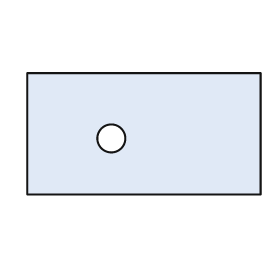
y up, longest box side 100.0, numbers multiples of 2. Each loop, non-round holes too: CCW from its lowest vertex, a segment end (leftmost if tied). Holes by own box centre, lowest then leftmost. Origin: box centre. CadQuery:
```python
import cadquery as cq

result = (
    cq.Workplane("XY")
    .moveTo(-50.0, -26.0)
    .lineTo(50.0, -26.0)
    .lineTo(50.0, 26.0)
    .lineTo(-50.0, 26.0)
    .close()
    .moveTo(-14.0, -2.0)
    .circle(6.0)
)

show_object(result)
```